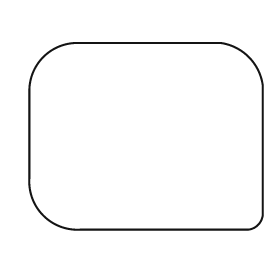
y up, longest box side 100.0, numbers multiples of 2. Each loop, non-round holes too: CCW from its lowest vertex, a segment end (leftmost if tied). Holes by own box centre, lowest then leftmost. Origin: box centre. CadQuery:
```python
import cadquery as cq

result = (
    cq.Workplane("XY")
    .moveTo(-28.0, -40.0)
    .lineTo(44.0, -40.0)
    .threePointArc((48.0, -38.0), (50.0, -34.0))
    .lineTo(50.0, 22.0)
    .threePointArc((44.0, 34.0), (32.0, 40.0))
    .lineTo(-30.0, 40.0)
    .threePointArc((-44.0, 34.0), (-50.0, 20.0))
    .lineTo(-50.0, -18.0)
    .threePointArc((-44.0, -34.0), (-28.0, -40.0))
    .close()
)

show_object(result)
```